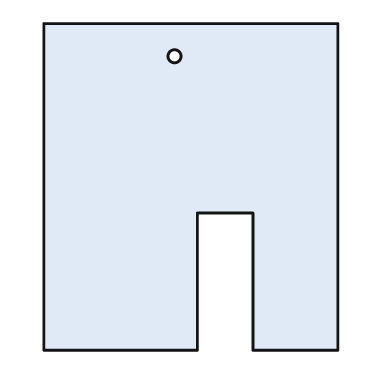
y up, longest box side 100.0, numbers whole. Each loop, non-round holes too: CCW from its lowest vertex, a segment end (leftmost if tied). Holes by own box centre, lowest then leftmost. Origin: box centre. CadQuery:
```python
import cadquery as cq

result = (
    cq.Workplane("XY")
    .moveTo(-45.0, -50.0)
    .lineTo(2.0, -50.0)
    .lineTo(2.0, -8.0)
    .lineTo(19.0, -8.0)
    .lineTo(19.0, -50.0)
    .lineTo(45.0, -50.0)
    .lineTo(45.0, 50.0)
    .lineTo(-45.0, 50.0)
    .close()
    .moveTo(-5.0, 40.0)
    .circle(2.0)
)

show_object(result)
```